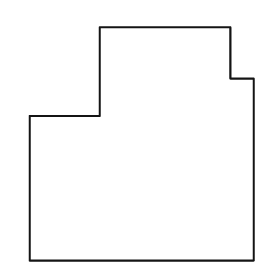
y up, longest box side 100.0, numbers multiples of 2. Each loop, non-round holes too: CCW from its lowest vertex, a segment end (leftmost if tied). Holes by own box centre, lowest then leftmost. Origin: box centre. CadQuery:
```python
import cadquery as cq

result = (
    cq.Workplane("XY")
    .moveTo(-48.0, -50.0)
    .lineTo(48.0, -50.0)
    .lineTo(48.0, 28.0)
    .lineTo(38.0, 28.0)
    .lineTo(38.0, 50.0)
    .lineTo(-18.0, 50.0)
    .lineTo(-18.0, 12.0)
    .lineTo(-48.0, 12.0)
    .close()
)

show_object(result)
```